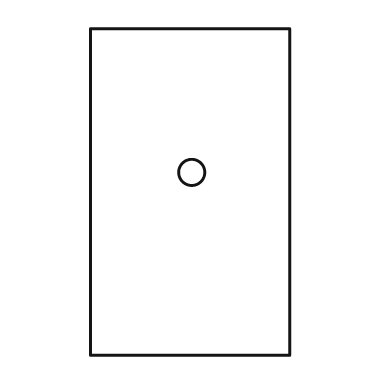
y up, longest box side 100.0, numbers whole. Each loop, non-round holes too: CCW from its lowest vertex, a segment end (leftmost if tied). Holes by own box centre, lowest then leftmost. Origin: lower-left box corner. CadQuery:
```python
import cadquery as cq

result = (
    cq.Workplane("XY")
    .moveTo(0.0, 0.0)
    .lineTo(61.0, 0.0)
    .lineTo(61.0, 100.0)
    .lineTo(0.0, 100.0)
    .close()
    .moveTo(31.0, 56.0)
    .circle(4.0)
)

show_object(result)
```